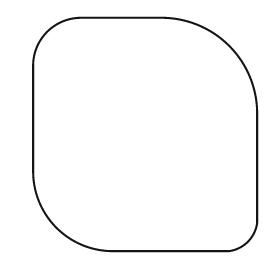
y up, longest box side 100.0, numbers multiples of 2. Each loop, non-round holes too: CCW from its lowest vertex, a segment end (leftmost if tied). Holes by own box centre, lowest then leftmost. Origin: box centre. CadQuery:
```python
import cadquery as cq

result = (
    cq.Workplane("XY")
    .moveTo(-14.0, -50.0)
    .lineTo(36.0, -50.0)
    .threePointArc((44.0, -46.0), (48.0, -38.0))
    .lineTo(48.0, 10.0)
    .threePointArc((36.0, 38.0), (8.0, 50.0))
    .lineTo(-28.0, 50.0)
    .threePointArc((-42.0, 44.0), (-48.0, 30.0))
    .lineTo(-48.0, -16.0)
    .threePointArc((-38.0, -40.0), (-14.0, -50.0))
    .close()
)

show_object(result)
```